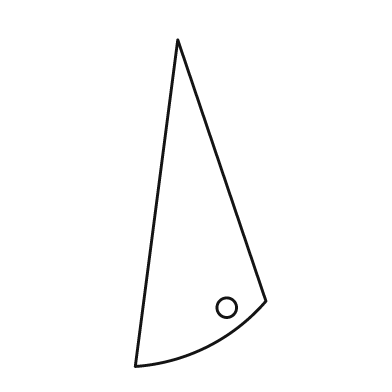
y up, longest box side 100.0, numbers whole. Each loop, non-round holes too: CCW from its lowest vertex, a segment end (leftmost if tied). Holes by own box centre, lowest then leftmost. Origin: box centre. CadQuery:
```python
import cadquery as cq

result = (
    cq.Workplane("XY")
    .moveTo(-20.0, -50.0)
    .threePointArc((2.0, -44.0), (20.0, -30.0))
    .lineTo(-7.0, 50.0)
    .close()
    .moveTo(8.0, -32.0)
    .circle(3.0)
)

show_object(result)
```